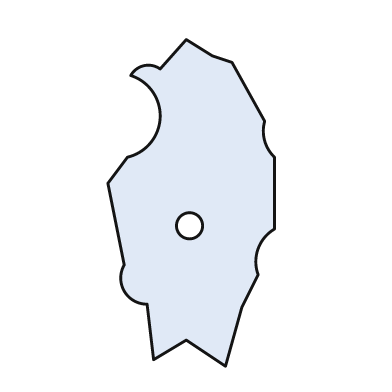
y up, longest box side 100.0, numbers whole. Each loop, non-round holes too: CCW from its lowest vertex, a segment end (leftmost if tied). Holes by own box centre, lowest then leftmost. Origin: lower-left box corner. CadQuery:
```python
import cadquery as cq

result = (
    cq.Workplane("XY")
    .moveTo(36.0, 0.0)
    .lineTo(41.0, 18.0)
    .lineTo(46.0, 28.0)
    .threePointArc((46.0, 36.0), (51.0, 42.0))
    .lineTo(51.0, 64.0)
    .threePointArc((48.0, 69.0), (48.0, 75.0))
    .lineTo(38.0, 93.0)
    .lineTo(32.0, 95.0)
    .lineTo(24.0, 100.0)
    .lineTo(16.0, 91.0)
    .threePointArc((11.0, 92.0), (7.0, 89.0))
    .threePointArc((16.0, 76.0), (6.0, 64.0))
    .lineTo(0.0, 56.0)
    .lineTo(5.0, 31.0)
    .threePointArc((5.0, 23.0), (12.0, 19.0))
    .lineTo(14.0, 2.0)
    .lineTo(24.0, 8.0)
    .close()
    .moveTo(25.0, 43.0)
    .circle(4.0)
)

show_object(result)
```